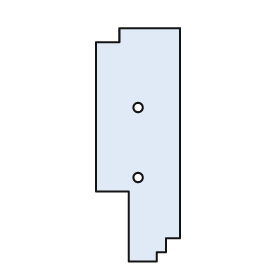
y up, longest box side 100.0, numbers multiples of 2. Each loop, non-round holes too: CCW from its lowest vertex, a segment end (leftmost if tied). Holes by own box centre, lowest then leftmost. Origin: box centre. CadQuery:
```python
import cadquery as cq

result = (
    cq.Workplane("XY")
    .moveTo(-4.0, -50.0)
    .lineTo(8.0, -50.0)
    .lineTo(8.0, -46.0)
    .lineTo(12.0, -46.0)
    .lineTo(12.0, -40.0)
    .lineTo(18.0, -40.0)
    .lineTo(18.0, 50.0)
    .lineTo(-8.0, 50.0)
    .lineTo(-8.0, 44.0)
    .lineTo(-18.0, 44.0)
    .lineTo(-18.0, -20.0)
    .lineTo(-4.0, -20.0)
    .close()
    .moveTo(0.0, -14.0)
    .circle(2.0)
    .moveTo(0.0, 16.0)
    .circle(2.0)
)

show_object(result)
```